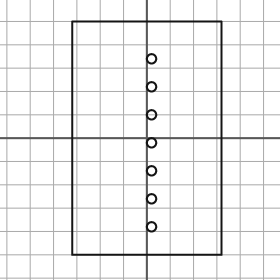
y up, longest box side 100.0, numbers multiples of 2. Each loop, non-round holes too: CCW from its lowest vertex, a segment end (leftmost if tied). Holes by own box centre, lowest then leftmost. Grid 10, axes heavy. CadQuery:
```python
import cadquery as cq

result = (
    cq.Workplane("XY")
    .moveTo(-32.0, -50.0)
    .lineTo(32.0, -50.0)
    .lineTo(32.0, 50.0)
    .lineTo(-32.0, 50.0)
    .close()
    .moveTo(2.0, -38.0)
    .circle(2.0)
    .moveTo(2.0, -26.0)
    .circle(2.0)
    .moveTo(2.0, -14.0)
    .circle(2.0)
    .moveTo(2.0, -2.0)
    .circle(2.0)
    .moveTo(2.0, 10.0)
    .circle(2.0)
    .moveTo(2.0, 22.0)
    .circle(2.0)
    .moveTo(2.0, 34.0)
    .circle(2.0)
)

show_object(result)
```